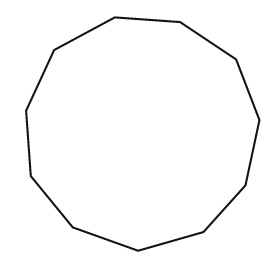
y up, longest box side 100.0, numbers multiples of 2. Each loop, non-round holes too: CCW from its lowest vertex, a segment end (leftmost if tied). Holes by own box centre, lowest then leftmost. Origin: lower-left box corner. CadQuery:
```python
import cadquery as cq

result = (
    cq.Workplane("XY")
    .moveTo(48.0, 0.0)
    .lineTo(76.0, 8.0)
    .lineTo(94.0, 28.0)
    .lineTo(100.0, 56.0)
    .lineTo(90.0, 82.0)
    .lineTo(66.0, 98.0)
    .lineTo(38.0, 100.0)
    .lineTo(12.0, 86.0)
    .lineTo(0.0, 60.0)
    .lineTo(2.0, 32.0)
    .lineTo(20.0, 10.0)
    .close()
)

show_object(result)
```